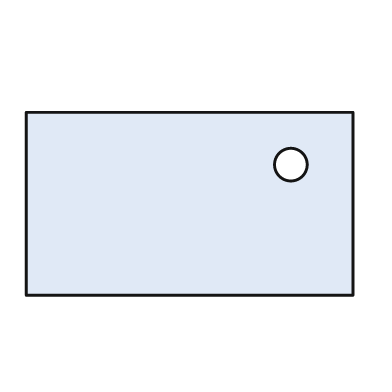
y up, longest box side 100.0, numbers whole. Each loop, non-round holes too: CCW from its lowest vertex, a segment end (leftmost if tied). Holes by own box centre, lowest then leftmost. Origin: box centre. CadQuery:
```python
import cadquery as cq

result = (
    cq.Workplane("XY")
    .moveTo(-50.0, -28.0)
    .lineTo(50.0, -28.0)
    .lineTo(50.0, 28.0)
    .lineTo(-50.0, 28.0)
    .close()
    .moveTo(31.0, 12.0)
    .circle(5.0)
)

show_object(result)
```